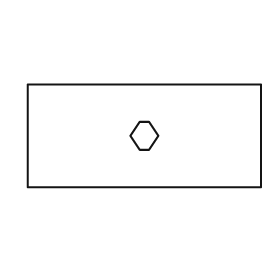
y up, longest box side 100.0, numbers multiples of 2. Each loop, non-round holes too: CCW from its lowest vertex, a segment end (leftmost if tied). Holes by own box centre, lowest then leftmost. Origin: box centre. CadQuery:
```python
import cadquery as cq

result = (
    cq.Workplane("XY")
    .moveTo(-50.0, -22.0)
    .lineTo(50.0, -22.0)
    .lineTo(50.0, 22.0)
    .lineTo(-50.0, 22.0)
    .close()
    .moveTo(-2.0, -6.0)
    .lineTo(2.0, -6.0)
    .lineTo(6.0, 0.0)
    .lineTo(2.0, 6.0)
    .lineTo(-2.0, 6.0)
    .lineTo(-6.0, 0.0)
    .close()
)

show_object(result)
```